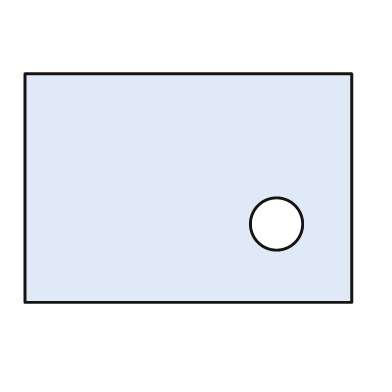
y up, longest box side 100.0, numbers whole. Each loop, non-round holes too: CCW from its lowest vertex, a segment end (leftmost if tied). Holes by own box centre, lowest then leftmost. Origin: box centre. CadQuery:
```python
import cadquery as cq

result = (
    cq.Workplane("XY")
    .moveTo(-50.0, -35.0)
    .lineTo(50.0, -35.0)
    .lineTo(50.0, 35.0)
    .lineTo(-50.0, 35.0)
    .close()
    .moveTo(27.0, -11.0)
    .circle(8.0)
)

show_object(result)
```